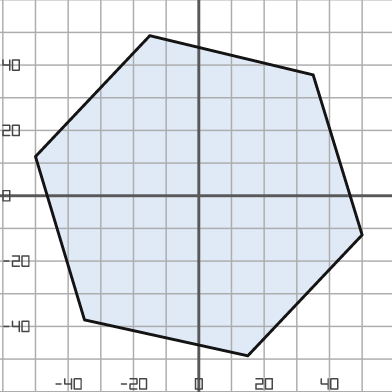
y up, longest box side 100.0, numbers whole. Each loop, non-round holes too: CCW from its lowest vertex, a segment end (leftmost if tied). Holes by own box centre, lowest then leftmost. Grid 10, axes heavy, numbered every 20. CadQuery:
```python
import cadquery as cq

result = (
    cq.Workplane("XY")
    .moveTo(15.0, -49.0)
    .lineTo(50.0, -12.0)
    .lineTo(35.0, 37.0)
    .lineTo(-15.0, 49.0)
    .lineTo(-50.0, 12.0)
    .lineTo(-35.0, -38.0)
    .close()
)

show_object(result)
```